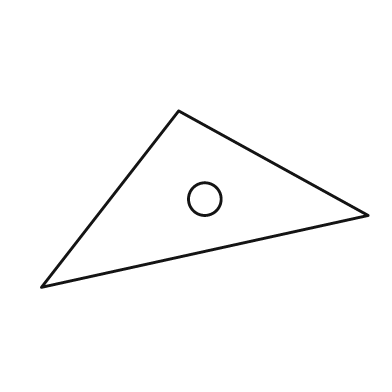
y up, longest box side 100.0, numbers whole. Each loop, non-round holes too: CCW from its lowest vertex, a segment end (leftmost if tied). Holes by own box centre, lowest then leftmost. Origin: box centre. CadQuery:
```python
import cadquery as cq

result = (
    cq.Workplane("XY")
    .moveTo(-50.0, -27.0)
    .lineTo(50.0, -5.0)
    .lineTo(-8.0, 27.0)
    .close()
    .moveTo(0.0, 0.0)
    .circle(5.0)
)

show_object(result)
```